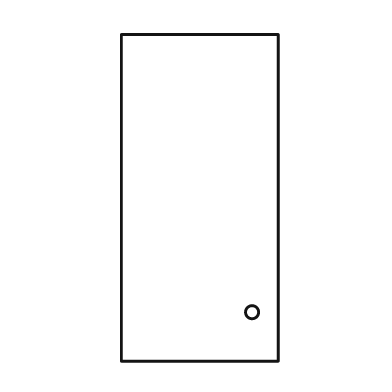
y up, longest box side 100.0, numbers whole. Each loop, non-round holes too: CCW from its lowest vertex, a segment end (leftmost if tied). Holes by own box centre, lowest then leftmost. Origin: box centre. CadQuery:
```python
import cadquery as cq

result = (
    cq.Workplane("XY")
    .moveTo(-24.0, -50.0)
    .lineTo(24.0, -50.0)
    .lineTo(24.0, 50.0)
    .lineTo(-24.0, 50.0)
    .close()
    .moveTo(16.0, -35.0)
    .circle(2.0)
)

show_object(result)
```